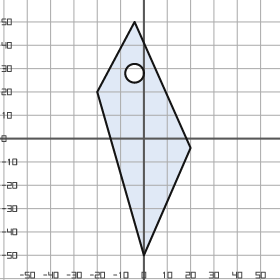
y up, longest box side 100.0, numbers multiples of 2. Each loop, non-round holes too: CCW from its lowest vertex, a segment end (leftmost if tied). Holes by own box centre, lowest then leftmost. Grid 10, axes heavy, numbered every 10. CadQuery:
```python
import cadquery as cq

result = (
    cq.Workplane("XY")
    .moveTo(0.0, -50.0)
    .lineTo(20.0, -4.0)
    .lineTo(-4.0, 50.0)
    .lineTo(-20.0, 20.0)
    .close()
    .moveTo(-4.0, 28.0)
    .circle(4.0)
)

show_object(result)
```